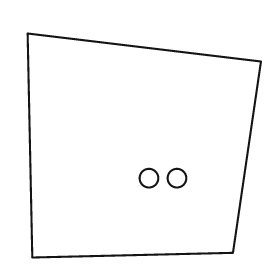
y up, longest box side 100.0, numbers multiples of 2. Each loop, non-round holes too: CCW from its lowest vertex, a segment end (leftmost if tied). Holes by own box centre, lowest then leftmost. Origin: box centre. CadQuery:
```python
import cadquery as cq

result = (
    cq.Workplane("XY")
    .moveTo(-48.0, -48.0)
    .lineTo(38.0, -46.0)
    .lineTo(50.0, 36.0)
    .lineTo(-50.0, 48.0)
    .close()
    .moveTo(2.0, -14.0)
    .circle(4.0)
    .moveTo(14.0, -14.0)
    .circle(4.0)
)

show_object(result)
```